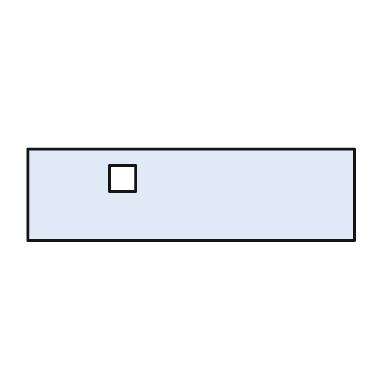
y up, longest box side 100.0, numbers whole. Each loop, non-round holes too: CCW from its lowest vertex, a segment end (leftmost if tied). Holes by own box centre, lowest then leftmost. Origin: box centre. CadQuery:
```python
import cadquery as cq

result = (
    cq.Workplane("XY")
    .moveTo(-50.0, -14.0)
    .lineTo(50.0, -14.0)
    .lineTo(50.0, 14.0)
    .lineTo(-50.0, 14.0)
    .close()
    .moveTo(-25.0, 1.0)
    .lineTo(-17.0, 1.0)
    .lineTo(-17.0, 9.0)
    .lineTo(-25.0, 9.0)
    .close()
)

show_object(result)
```